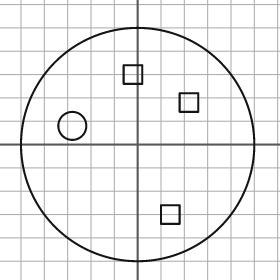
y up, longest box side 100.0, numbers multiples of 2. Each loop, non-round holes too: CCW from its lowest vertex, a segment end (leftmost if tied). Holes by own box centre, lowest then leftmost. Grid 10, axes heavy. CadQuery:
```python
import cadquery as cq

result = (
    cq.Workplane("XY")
    .moveTo(0.0, 0.0)
    .circle(50.0)
    .moveTo(10.0, -34.0)
    .lineTo(18.0, -34.0)
    .lineTo(18.0, -26.0)
    .lineTo(10.0, -26.0)
    .close()
    .moveTo(-28.0, 8.0)
    .circle(6.0)
    .moveTo(18.0, 14.0)
    .lineTo(26.0, 14.0)
    .lineTo(26.0, 22.0)
    .lineTo(18.0, 22.0)
    .close()
    .moveTo(-6.0, 26.0)
    .lineTo(2.0, 26.0)
    .lineTo(2.0, 34.0)
    .lineTo(-6.0, 34.0)
    .close()
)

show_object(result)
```